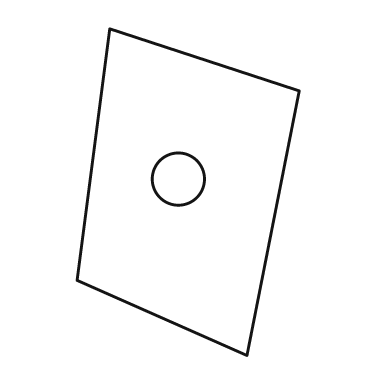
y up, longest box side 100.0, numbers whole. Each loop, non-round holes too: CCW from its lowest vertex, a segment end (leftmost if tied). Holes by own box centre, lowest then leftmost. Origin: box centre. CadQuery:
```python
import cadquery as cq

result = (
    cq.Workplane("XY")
    .moveTo(18.0, -50.0)
    .lineTo(34.0, 31.0)
    .lineTo(-24.0, 50.0)
    .lineTo(-34.0, -27.0)
    .close()
    .moveTo(-3.0, 4.0)
    .circle(8.0)
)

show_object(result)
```